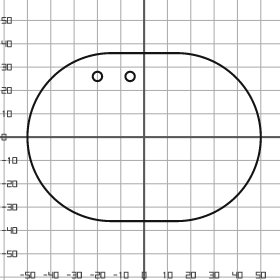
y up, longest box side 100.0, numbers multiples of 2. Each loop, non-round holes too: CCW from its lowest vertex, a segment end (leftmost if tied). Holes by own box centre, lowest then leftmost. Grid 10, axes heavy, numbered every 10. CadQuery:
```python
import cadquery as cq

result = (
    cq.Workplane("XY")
    .moveTo(-14.0, -36.0)
    .lineTo(14.0, -36.0)
    .threePointArc((50.0, 0.0), (14.0, 36.0))
    .lineTo(-14.0, 36.0)
    .threePointArc((-50.0, 0.0), (-14.0, -36.0))
    .close()
    .moveTo(-20.0, 26.0)
    .circle(2.0)
    .moveTo(-6.0, 26.0)
    .circle(2.0)
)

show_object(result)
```